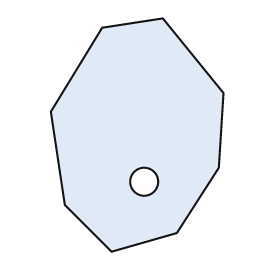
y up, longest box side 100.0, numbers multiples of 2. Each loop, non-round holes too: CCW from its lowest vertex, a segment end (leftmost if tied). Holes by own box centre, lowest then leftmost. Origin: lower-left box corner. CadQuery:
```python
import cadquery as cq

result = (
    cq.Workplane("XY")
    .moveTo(26.0, 0.0)
    .lineTo(54.0, 8.0)
    .lineTo(72.0, 36.0)
    .lineTo(74.0, 68.0)
    .lineTo(48.0, 100.0)
    .lineTo(22.0, 96.0)
    .lineTo(0.0, 60.0)
    .lineTo(6.0, 20.0)
    .close()
    .moveTo(40.0, 30.0)
    .circle(6.0)
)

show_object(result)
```